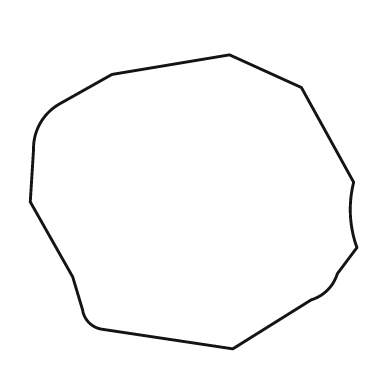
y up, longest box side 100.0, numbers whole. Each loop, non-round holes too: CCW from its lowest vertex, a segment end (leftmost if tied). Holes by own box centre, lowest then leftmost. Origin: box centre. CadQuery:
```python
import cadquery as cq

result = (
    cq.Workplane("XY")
    .moveTo(12.0, -45.0)
    .lineTo(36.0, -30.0)
    .threePointArc((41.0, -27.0), (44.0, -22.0))
    .lineTo(50.0, -14.0)
    .threePointArc((48.0, -4.0), (49.0, 6.0))
    .lineTo(33.0, 35.0)
    .lineTo(11.0, 45.0)
    .lineTo(-25.0, 39.0)
    .lineTo(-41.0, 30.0)
    .threePointArc((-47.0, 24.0), (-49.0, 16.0))
    .lineTo(-50.0, 0.0)
    .lineTo(-37.0, -23.0)
    .lineTo(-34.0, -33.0)
    .threePointArc((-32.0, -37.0), (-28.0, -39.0))
    .close()
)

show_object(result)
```